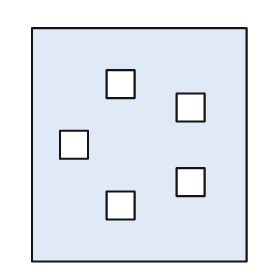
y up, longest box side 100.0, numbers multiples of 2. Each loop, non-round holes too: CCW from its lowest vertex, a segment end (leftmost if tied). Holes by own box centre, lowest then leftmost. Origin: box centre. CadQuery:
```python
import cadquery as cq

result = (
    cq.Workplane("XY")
    .moveTo(-46.0, -50.0)
    .lineTo(46.0, -50.0)
    .lineTo(46.0, 50.0)
    .lineTo(-46.0, 50.0)
    .close()
    .moveTo(-14.0, -32.0)
    .lineTo(-2.0, -32.0)
    .lineTo(-2.0, -20.0)
    .lineTo(-14.0, -20.0)
    .close()
    .moveTo(16.0, -22.0)
    .lineTo(28.0, -22.0)
    .lineTo(28.0, -10.0)
    .lineTo(16.0, -10.0)
    .close()
    .moveTo(-34.0, -6.0)
    .lineTo(-22.0, -6.0)
    .lineTo(-22.0, 6.0)
    .lineTo(-34.0, 6.0)
    .close()
    .moveTo(16.0, 10.0)
    .lineTo(28.0, 10.0)
    .lineTo(28.0, 22.0)
    .lineTo(16.0, 22.0)
    .close()
    .moveTo(-14.0, 20.0)
    .lineTo(-2.0, 20.0)
    .lineTo(-2.0, 32.0)
    .lineTo(-14.0, 32.0)
    .close()
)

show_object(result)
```